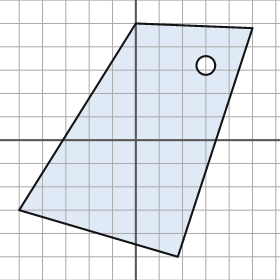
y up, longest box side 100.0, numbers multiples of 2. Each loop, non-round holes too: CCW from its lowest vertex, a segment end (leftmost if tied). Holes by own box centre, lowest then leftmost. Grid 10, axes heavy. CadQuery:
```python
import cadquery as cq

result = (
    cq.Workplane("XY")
    .moveTo(18.0, -50.0)
    .lineTo(50.0, 48.0)
    .lineTo(0.0, 50.0)
    .lineTo(-50.0, -30.0)
    .close()
    .moveTo(30.0, 32.0)
    .circle(4.0)
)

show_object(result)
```